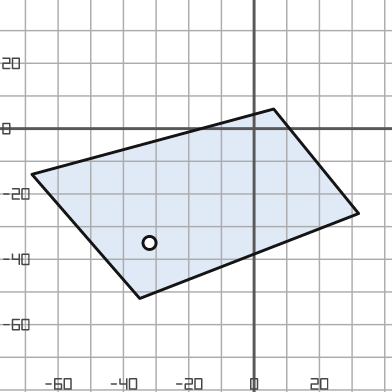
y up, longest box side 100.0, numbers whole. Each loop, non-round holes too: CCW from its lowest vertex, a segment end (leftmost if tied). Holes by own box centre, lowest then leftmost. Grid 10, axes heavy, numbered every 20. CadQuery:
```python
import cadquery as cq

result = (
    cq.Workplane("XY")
    .moveTo(-35.0, -52.0)
    .lineTo(32.0, -26.0)
    .lineTo(6.0, 6.0)
    .lineTo(-68.0, -14.0)
    .close()
    .moveTo(-32.0, -35.0)
    .circle(2.0)
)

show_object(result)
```